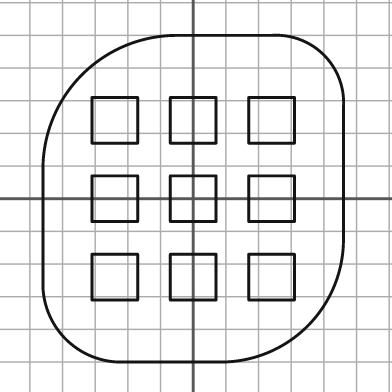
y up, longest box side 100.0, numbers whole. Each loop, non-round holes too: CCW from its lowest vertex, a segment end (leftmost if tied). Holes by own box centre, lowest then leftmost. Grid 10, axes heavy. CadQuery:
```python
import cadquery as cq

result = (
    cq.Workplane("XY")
    .moveTo(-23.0, -50.0)
    .lineTo(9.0, -50.0)
    .threePointArc((35.0, -39.0), (46.0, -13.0))
    .lineTo(46.0, 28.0)
    .threePointArc((40.0, 44.0), (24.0, 50.0))
    .lineTo(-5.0, 50.0)
    .threePointArc((-34.0, 38.0), (-46.0, 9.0))
    .lineTo(-46.0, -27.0)
    .threePointArc((-39.0, -43.0), (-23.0, -50.0))
    .close()
    .moveTo(-31.0, -31.0)
    .lineTo(-17.0, -31.0)
    .lineTo(-17.0, -17.0)
    .lineTo(-31.0, -17.0)
    .close()
    .moveTo(-7.0, -31.0)
    .lineTo(7.0, -31.0)
    .lineTo(7.0, -17.0)
    .lineTo(-7.0, -17.0)
    .close()
    .moveTo(17.0, -31.0)
    .lineTo(31.0, -31.0)
    .lineTo(31.0, -17.0)
    .lineTo(17.0, -17.0)
    .close()
    .moveTo(-31.0, -7.0)
    .lineTo(-17.0, -7.0)
    .lineTo(-17.0, 7.0)
    .lineTo(-31.0, 7.0)
    .close()
    .moveTo(-7.0, -7.0)
    .lineTo(7.0, -7.0)
    .lineTo(7.0, 7.0)
    .lineTo(-7.0, 7.0)
    .close()
    .moveTo(17.0, -7.0)
    .lineTo(31.0, -7.0)
    .lineTo(31.0, 7.0)
    .lineTo(17.0, 7.0)
    .close()
    .moveTo(-31.0, 17.0)
    .lineTo(-17.0, 17.0)
    .lineTo(-17.0, 31.0)
    .lineTo(-31.0, 31.0)
    .close()
    .moveTo(-7.0, 17.0)
    .lineTo(7.0, 17.0)
    .lineTo(7.0, 31.0)
    .lineTo(-7.0, 31.0)
    .close()
    .moveTo(17.0, 17.0)
    .lineTo(31.0, 17.0)
    .lineTo(31.0, 31.0)
    .lineTo(17.0, 31.0)
    .close()
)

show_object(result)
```